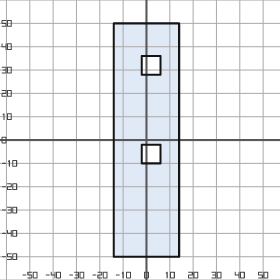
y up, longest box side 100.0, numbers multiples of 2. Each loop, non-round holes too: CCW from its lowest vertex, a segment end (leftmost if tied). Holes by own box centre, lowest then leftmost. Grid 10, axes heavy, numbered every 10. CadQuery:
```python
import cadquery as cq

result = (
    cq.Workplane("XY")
    .moveTo(-14.0, -50.0)
    .lineTo(14.0, -50.0)
    .lineTo(14.0, 50.0)
    .lineTo(-14.0, 50.0)
    .close()
    .moveTo(-2.0, -10.0)
    .lineTo(6.0, -10.0)
    .lineTo(6.0, -2.0)
    .lineTo(-2.0, -2.0)
    .close()
    .moveTo(-2.0, 28.0)
    .lineTo(6.0, 28.0)
    .lineTo(6.0, 36.0)
    .lineTo(-2.0, 36.0)
    .close()
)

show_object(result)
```